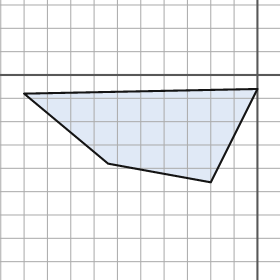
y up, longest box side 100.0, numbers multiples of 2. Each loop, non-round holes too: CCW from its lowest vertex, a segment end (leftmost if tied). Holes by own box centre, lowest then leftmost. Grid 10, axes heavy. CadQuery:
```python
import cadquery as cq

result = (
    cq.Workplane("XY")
    .moveTo(-20.0, -46.0)
    .lineTo(0.0, -6.0)
    .lineTo(-100.0, -8.0)
    .lineTo(-64.0, -38.0)
    .close()
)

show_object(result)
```